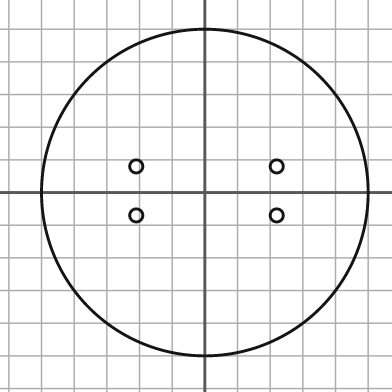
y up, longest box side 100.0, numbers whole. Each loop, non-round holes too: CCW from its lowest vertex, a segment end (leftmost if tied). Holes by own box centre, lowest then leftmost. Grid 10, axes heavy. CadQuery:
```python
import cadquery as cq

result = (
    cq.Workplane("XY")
    .moveTo(0.0, 0.0)
    .circle(50.0)
    .moveTo(-21.0, -7.0)
    .circle(2.0)
    .moveTo(22.0, -7.0)
    .circle(2.0)
    .moveTo(-21.0, 8.0)
    .circle(2.0)
    .moveTo(22.0, 8.0)
    .circle(2.0)
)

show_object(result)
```